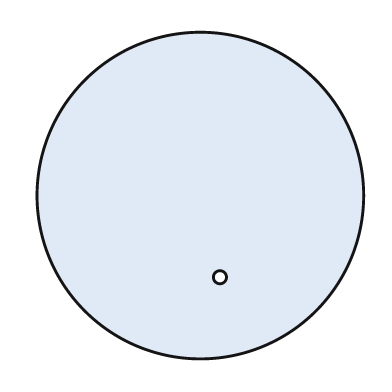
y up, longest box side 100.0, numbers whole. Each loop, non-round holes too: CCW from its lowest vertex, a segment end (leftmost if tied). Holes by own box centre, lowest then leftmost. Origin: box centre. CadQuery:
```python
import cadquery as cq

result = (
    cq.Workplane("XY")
    .moveTo(0.0, 0.0)
    .circle(50.0)
    .moveTo(6.0, -25.0)
    .circle(2.0)
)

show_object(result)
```